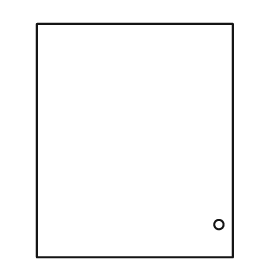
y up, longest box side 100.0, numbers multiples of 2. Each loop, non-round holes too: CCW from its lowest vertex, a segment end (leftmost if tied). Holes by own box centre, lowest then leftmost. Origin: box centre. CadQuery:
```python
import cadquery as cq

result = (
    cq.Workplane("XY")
    .moveTo(-42.0, -50.0)
    .lineTo(42.0, -50.0)
    .lineTo(42.0, 50.0)
    .lineTo(-42.0, 50.0)
    .close()
    .moveTo(36.0, -36.0)
    .circle(2.0)
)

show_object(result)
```